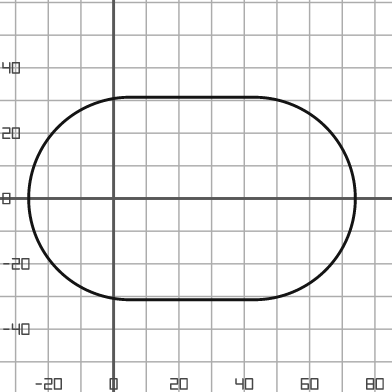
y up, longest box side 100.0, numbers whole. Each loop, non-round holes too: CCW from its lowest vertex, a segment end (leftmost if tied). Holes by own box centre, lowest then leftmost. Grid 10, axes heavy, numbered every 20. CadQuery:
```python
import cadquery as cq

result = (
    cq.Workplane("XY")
    .moveTo(5.0, -31.0)
    .lineTo(43.0, -31.0)
    .threePointArc((74.0, 0.0), (43.0, 31.0))
    .lineTo(5.0, 31.0)
    .threePointArc((-26.0, 0.0), (5.0, -31.0))
    .close()
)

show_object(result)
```